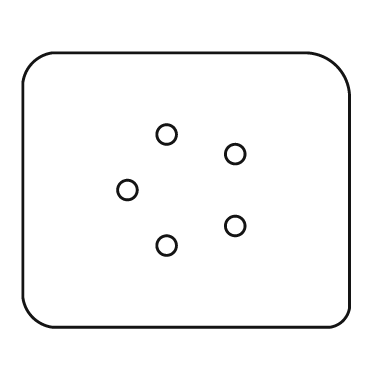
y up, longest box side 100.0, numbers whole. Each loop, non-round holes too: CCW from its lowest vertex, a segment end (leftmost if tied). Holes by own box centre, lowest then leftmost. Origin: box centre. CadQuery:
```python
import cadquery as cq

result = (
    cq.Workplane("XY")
    .moveTo(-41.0, -42.0)
    .lineTo(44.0, -42.0)
    .threePointArc((48.0, -40.0), (50.0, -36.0))
    .lineTo(50.0, 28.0)
    .threePointArc((46.0, 38.0), (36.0, 42.0))
    .lineTo(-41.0, 42.0)
    .threePointArc((-47.0, 39.0), (-50.0, 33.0))
    .lineTo(-50.0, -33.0)
    .threePointArc((-47.0, -39.0), (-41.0, -42.0))
    .close()
    .moveTo(-6.0, -17.0)
    .circle(3.0)
    .moveTo(15.0, -11.0)
    .circle(3.0)
    .moveTo(-18.0, 0.0)
    .circle(3.0)
    .moveTo(15.0, 11.0)
    .circle(3.0)
    .moveTo(-6.0, 17.0)
    .circle(3.0)
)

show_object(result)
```